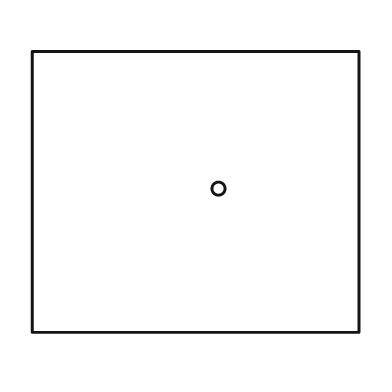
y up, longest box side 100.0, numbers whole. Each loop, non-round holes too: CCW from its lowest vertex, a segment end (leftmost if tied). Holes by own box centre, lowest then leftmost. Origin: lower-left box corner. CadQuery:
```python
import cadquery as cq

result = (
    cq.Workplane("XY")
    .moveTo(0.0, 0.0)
    .lineTo(100.0, 0.0)
    .lineTo(100.0, 86.0)
    .lineTo(0.0, 86.0)
    .close()
    .moveTo(57.0, 44.0)
    .circle(2.0)
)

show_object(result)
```